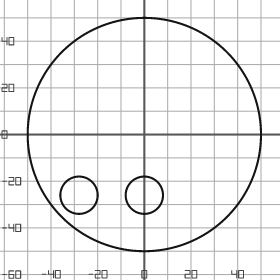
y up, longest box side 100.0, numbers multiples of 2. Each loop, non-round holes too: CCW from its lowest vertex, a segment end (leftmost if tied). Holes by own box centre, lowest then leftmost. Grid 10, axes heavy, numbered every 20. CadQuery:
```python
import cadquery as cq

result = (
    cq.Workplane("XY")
    .moveTo(0.0, 0.0)
    .circle(50.0)
    .moveTo(-28.0, -26.0)
    .circle(8.0)
    .moveTo(0.0, -26.0)
    .circle(8.0)
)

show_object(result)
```